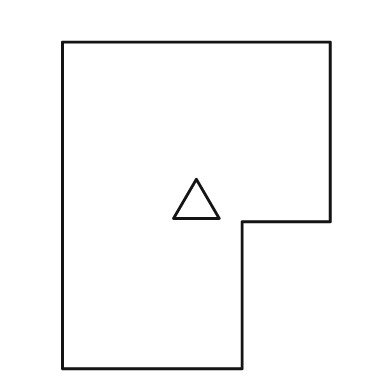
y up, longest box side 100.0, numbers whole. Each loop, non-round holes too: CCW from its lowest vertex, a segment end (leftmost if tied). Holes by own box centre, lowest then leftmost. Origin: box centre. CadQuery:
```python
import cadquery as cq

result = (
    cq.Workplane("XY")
    .moveTo(-41.0, -50.0)
    .lineTo(14.0, -50.0)
    .lineTo(14.0, -5.0)
    .lineTo(41.0, -5.0)
    .lineTo(41.0, 50.0)
    .lineTo(-41.0, 50.0)
    .close()
    .moveTo(-7.0, -4.0)
    .lineTo(7.0, -4.0)
    .lineTo(0.0, 8.0)
    .close()
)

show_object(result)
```